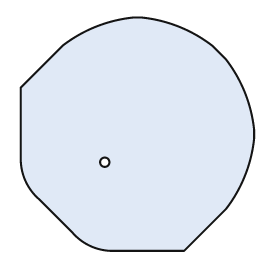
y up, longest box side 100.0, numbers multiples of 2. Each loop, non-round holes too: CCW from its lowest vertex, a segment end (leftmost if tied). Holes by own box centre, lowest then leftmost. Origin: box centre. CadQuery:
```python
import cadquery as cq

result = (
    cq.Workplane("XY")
    .moveTo(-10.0, -50.0)
    .lineTo(20.0, -50.0)
    .lineTo(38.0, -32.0)
    .threePointArc((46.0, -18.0), (50.0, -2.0))
    .lineTo(50.0, 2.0)
    .threePointArc((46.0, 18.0), (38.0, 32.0))
    .lineTo(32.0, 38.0)
    .threePointArc((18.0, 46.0), (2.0, 50.0))
    .lineTo(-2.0, 50.0)
    .threePointArc((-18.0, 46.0), (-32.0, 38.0))
    .lineTo(-50.0, 20.0)
    .lineTo(-50.0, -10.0)
    .threePointArc((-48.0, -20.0), (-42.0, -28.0))
    .lineTo(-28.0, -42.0)
    .threePointArc((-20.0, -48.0), (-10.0, -50.0))
    .close()
    .moveTo(-14.0, -12.0)
    .circle(2.0)
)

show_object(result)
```